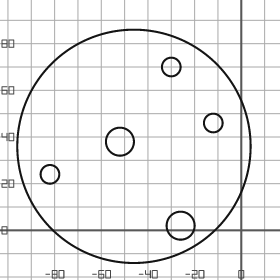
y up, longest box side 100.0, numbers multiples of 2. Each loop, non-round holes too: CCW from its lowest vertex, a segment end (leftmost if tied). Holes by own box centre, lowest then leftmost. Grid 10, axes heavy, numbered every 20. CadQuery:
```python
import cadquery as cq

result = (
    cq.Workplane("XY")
    .moveTo(-46.0, 36.0)
    .circle(50.0)
    .moveTo(-26.0, 2.0)
    .circle(6.0)
    .moveTo(-82.0, 24.0)
    .circle(4.0)
    .moveTo(-52.0, 38.0)
    .circle(6.0)
    .moveTo(-12.0, 46.0)
    .circle(4.0)
    .moveTo(-30.0, 70.0)
    .circle(4.0)
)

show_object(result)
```